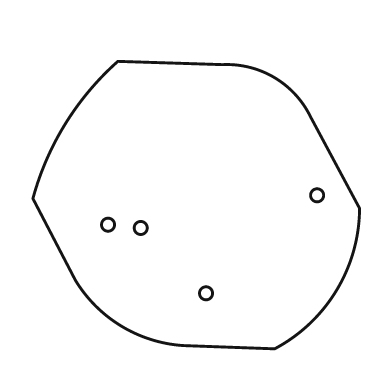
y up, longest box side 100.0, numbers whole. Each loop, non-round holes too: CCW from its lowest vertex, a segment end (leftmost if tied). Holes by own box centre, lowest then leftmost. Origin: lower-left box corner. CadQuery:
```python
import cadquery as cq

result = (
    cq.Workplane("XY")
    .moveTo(74.0, 0.0)
    .threePointArc((93.0, 18.0), (100.0, 43.0))
    .lineTo(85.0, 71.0)
    .threePointArc((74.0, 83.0), (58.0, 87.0))
    .lineTo(26.0, 88.0)
    .threePointArc((10.0, 69.0), (0.0, 46.0))
    .lineTo(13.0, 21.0)
    .threePointArc((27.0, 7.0), (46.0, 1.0))
    .close()
    .moveTo(53.0, 17.0)
    .circle(2.0)
    .moveTo(33.0, 37.0)
    .circle(2.0)
    .moveTo(23.0, 38.0)
    .circle(2.0)
    .moveTo(87.0, 47.0)
    .circle(2.0)
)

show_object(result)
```